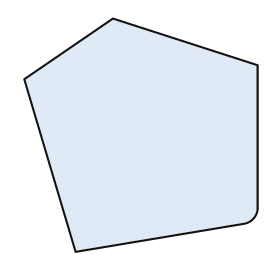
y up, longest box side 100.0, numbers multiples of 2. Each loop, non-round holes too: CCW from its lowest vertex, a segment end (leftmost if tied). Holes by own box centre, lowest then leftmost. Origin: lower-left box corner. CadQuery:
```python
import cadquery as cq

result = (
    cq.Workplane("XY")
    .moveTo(22.0, 0.0)
    .lineTo(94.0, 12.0)
    .threePointArc((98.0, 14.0), (100.0, 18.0))
    .lineTo(100.0, 80.0)
    .lineTo(38.0, 100.0)
    .lineTo(0.0, 74.0)
    .close()
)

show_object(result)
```